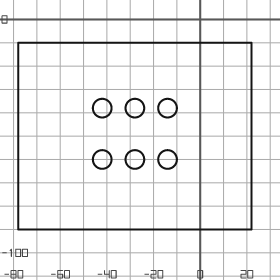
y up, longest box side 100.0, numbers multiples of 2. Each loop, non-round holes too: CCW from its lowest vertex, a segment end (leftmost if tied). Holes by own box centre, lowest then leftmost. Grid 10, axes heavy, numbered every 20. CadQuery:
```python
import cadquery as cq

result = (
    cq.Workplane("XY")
    .moveTo(-78.0, -90.0)
    .lineTo(22.0, -90.0)
    .lineTo(22.0, -10.0)
    .lineTo(-78.0, -10.0)
    .close()
    .moveTo(-42.0, -60.0)
    .circle(4.0)
    .moveTo(-28.0, -60.0)
    .circle(4.0)
    .moveTo(-14.0, -60.0)
    .circle(4.0)
    .moveTo(-42.0, -38.0)
    .circle(4.0)
    .moveTo(-28.0, -38.0)
    .circle(4.0)
    .moveTo(-14.0, -38.0)
    .circle(4.0)
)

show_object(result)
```